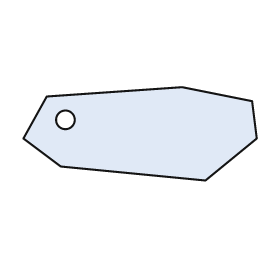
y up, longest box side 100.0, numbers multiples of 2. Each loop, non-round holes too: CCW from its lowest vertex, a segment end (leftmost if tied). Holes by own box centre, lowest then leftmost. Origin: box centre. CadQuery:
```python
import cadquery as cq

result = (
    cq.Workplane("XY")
    .moveTo(28.0, -20.0)
    .lineTo(50.0, -2.0)
    .lineTo(48.0, 14.0)
    .lineTo(18.0, 20.0)
    .lineTo(-40.0, 16.0)
    .lineTo(-50.0, -2.0)
    .lineTo(-34.0, -14.0)
    .close()
    .moveTo(-32.0, 6.0)
    .circle(4.0)
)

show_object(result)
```